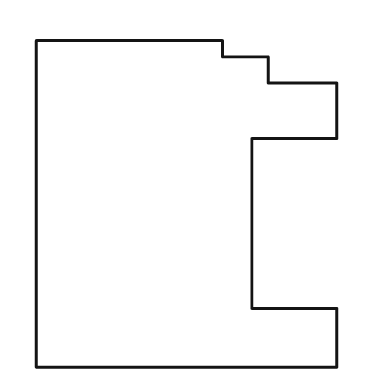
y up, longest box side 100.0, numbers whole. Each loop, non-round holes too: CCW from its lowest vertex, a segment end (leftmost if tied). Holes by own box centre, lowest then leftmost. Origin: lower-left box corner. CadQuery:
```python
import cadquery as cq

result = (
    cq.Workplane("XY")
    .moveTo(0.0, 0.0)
    .lineTo(92.0, 0.0)
    .lineTo(92.0, 18.0)
    .lineTo(66.0, 18.0)
    .lineTo(66.0, 70.0)
    .lineTo(92.0, 70.0)
    .lineTo(92.0, 87.0)
    .lineTo(71.0, 87.0)
    .lineTo(71.0, 95.0)
    .lineTo(57.0, 95.0)
    .lineTo(57.0, 100.0)
    .lineTo(0.0, 100.0)
    .close()
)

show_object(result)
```